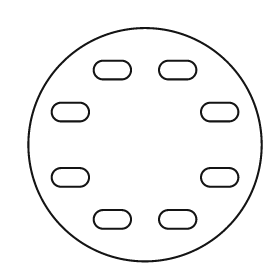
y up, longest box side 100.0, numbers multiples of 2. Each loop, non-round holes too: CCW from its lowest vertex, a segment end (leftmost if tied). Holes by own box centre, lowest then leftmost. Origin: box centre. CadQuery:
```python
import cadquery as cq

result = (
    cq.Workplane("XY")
    .moveTo(0.0, 0.0)
    .circle(50.0)
    .moveTo(-18.0, -36.0)
    .lineTo(-10.0, -36.0)
    .threePointArc((-6.0, -32.0), (-10.0, -28.0))
    .lineTo(-18.0, -28.0)
    .threePointArc((-22.0, -32.0), (-18.0, -36.0))
    .close()
    .moveTo(10.0, -36.0)
    .lineTo(18.0, -36.0)
    .threePointArc((22.0, -32.0), (18.0, -28.0))
    .lineTo(10.0, -28.0)
    .threePointArc((6.0, -32.0), (10.0, -36.0))
    .close()
    .moveTo(-36.0, -18.0)
    .lineTo(-28.0, -18.0)
    .threePointArc((-24.0, -14.0), (-28.0, -10.0))
    .lineTo(-36.0, -10.0)
    .threePointArc((-40.0, -14.0), (-36.0, -18.0))
    .close()
    .moveTo(28.0, -18.0)
    .lineTo(36.0, -18.0)
    .threePointArc((40.0, -14.0), (36.0, -10.0))
    .lineTo(28.0, -10.0)
    .threePointArc((24.0, -14.0), (28.0, -18.0))
    .close()
    .moveTo(-36.0, 10.0)
    .lineTo(-28.0, 10.0)
    .threePointArc((-24.0, 14.0), (-28.0, 18.0))
    .lineTo(-36.0, 18.0)
    .threePointArc((-40.0, 14.0), (-36.0, 10.0))
    .close()
    .moveTo(28.0, 10.0)
    .lineTo(36.0, 10.0)
    .threePointArc((40.0, 14.0), (36.0, 18.0))
    .lineTo(28.0, 18.0)
    .threePointArc((24.0, 14.0), (28.0, 10.0))
    .close()
    .moveTo(-18.0, 28.0)
    .lineTo(-10.0, 28.0)
    .threePointArc((-6.0, 32.0), (-10.0, 36.0))
    .lineTo(-18.0, 36.0)
    .threePointArc((-22.0, 32.0), (-18.0, 28.0))
    .close()
    .moveTo(10.0, 28.0)
    .lineTo(18.0, 28.0)
    .threePointArc((22.0, 32.0), (18.0, 36.0))
    .lineTo(10.0, 36.0)
    .threePointArc((6.0, 32.0), (10.0, 28.0))
    .close()
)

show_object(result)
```